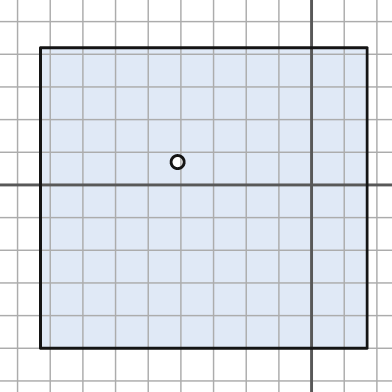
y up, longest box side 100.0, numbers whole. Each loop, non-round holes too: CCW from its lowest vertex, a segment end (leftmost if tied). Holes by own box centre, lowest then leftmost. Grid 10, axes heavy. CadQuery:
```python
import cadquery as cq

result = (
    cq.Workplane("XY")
    .moveTo(-83.0, -50.0)
    .lineTo(17.0, -50.0)
    .lineTo(17.0, 42.0)
    .lineTo(-83.0, 42.0)
    .close()
    .moveTo(-41.0, 7.0)
    .circle(2.0)
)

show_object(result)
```